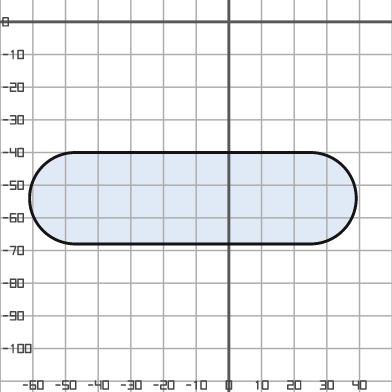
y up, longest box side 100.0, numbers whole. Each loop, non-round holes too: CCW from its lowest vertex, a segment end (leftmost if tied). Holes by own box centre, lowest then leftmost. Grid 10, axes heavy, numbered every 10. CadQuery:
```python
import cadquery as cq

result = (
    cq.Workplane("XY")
    .moveTo(-47.0, -68.0)
    .lineTo(25.0, -68.0)
    .threePointArc((39.0, -54.0), (25.0, -40.0))
    .lineTo(-47.0, -40.0)
    .threePointArc((-61.0, -54.0), (-47.0, -68.0))
    .close()
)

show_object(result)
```